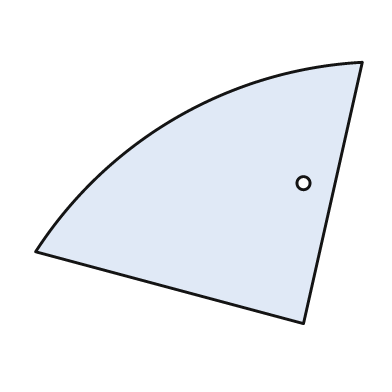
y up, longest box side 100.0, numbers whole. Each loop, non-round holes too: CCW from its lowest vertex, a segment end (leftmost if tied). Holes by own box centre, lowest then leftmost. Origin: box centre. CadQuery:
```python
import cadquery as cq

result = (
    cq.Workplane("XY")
    .moveTo(32.0, -40.0)
    .lineTo(50.0, 40.0)
    .threePointArc((-7.0, 23.0), (-50.0, -18.0))
    .close()
    .moveTo(32.0, 3.0)
    .circle(2.0)
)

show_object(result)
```